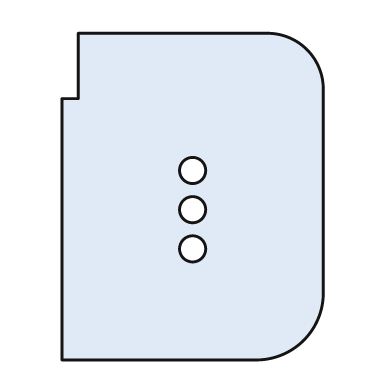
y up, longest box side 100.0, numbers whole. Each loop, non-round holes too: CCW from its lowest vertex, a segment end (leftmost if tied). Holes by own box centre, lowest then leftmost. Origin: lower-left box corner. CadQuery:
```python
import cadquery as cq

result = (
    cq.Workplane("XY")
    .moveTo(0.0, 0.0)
    .lineTo(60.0, 0.0)
    .threePointArc((74.0, 6.0), (80.0, 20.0))
    .lineTo(80.0, 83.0)
    .threePointArc((75.0, 95.0), (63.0, 100.0))
    .lineTo(5.0, 100.0)
    .lineTo(5.0, 80.0)
    .lineTo(0.0, 80.0)
    .close()
    .moveTo(40.0, 34.0)
    .circle(4.0)
    .moveTo(40.0, 46.0)
    .circle(4.0)
    .moveTo(40.0, 58.0)
    .circle(4.0)
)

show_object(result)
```